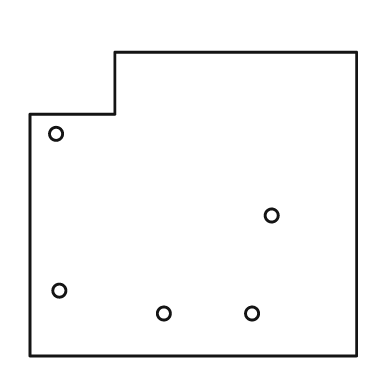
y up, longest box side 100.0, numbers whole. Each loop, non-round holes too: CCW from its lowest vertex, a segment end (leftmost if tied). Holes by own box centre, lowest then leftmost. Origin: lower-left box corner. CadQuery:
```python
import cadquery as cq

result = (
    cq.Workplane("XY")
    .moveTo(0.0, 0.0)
    .lineTo(100.0, 0.0)
    .lineTo(100.0, 93.0)
    .lineTo(26.0, 93.0)
    .lineTo(26.0, 74.0)
    .lineTo(0.0, 74.0)
    .close()
    .moveTo(41.0, 13.0)
    .circle(2.0)
    .moveTo(68.0, 13.0)
    .circle(2.0)
    .moveTo(9.0, 20.0)
    .circle(2.0)
    .moveTo(74.0, 43.0)
    .circle(2.0)
    .moveTo(8.0, 68.0)
    .circle(2.0)
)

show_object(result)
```